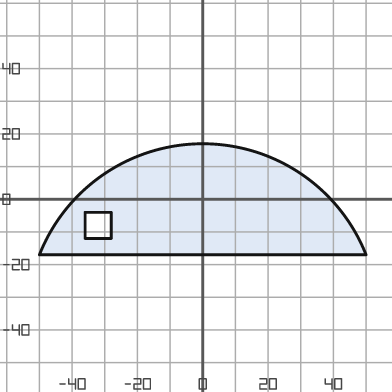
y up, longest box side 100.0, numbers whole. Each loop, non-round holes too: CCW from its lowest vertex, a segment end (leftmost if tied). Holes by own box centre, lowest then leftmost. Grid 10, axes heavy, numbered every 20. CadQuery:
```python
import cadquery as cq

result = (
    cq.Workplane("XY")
    .moveTo(-50.0, -17.0)
    .lineTo(50.0, -17.0)
    .threePointArc((0.0, 17.0), (-50.0, -17.0))
    .close()
    .moveTo(-36.0, -12.0)
    .lineTo(-28.0, -12.0)
    .lineTo(-28.0, -4.0)
    .lineTo(-36.0, -4.0)
    .close()
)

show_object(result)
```